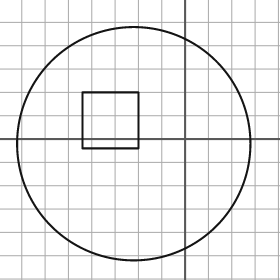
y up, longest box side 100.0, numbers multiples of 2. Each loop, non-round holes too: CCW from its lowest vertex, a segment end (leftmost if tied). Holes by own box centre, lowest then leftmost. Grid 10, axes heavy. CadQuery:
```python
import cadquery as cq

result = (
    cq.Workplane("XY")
    .moveTo(-22.0, -2.0)
    .circle(50.0)
    .moveTo(-44.0, -4.0)
    .lineTo(-20.0, -4.0)
    .lineTo(-20.0, 20.0)
    .lineTo(-44.0, 20.0)
    .close()
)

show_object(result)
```